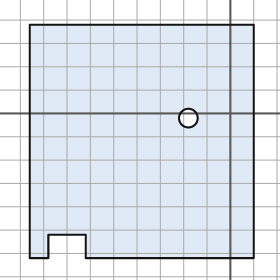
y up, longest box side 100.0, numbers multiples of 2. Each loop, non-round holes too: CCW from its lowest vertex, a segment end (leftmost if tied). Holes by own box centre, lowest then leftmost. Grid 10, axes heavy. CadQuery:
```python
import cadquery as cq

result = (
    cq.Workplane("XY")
    .moveTo(-86.0, -62.0)
    .lineTo(-78.0, -62.0)
    .lineTo(-78.0, -52.0)
    .lineTo(-62.0, -52.0)
    .lineTo(-62.0, -62.0)
    .lineTo(10.0, -62.0)
    .lineTo(10.0, 38.0)
    .lineTo(-86.0, 38.0)
    .close()
    .moveTo(-18.0, -2.0)
    .circle(4.0)
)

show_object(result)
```